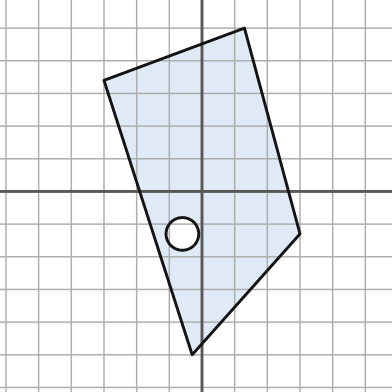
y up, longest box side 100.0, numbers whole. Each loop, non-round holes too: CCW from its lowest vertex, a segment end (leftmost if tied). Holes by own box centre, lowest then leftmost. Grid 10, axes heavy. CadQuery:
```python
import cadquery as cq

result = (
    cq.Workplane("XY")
    .moveTo(-3.0, -50.0)
    .lineTo(30.0, -13.0)
    .lineTo(13.0, 50.0)
    .lineTo(-30.0, 34.0)
    .close()
    .moveTo(-6.0, -13.0)
    .circle(5.0)
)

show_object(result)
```